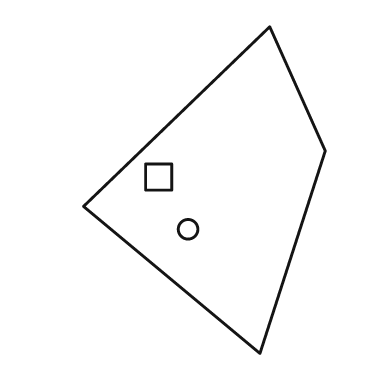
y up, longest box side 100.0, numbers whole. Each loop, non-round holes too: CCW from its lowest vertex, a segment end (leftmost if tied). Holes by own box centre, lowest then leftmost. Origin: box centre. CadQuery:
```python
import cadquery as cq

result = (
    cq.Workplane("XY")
    .moveTo(17.0, -50.0)
    .lineTo(37.0, 12.0)
    .lineTo(20.0, 50.0)
    .lineTo(-37.0, -5.0)
    .close()
    .moveTo(-5.0, -12.0)
    .circle(3.0)
    .moveTo(-18.0, 0.0)
    .lineTo(-10.0, 0.0)
    .lineTo(-10.0, 8.0)
    .lineTo(-18.0, 8.0)
    .close()
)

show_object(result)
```